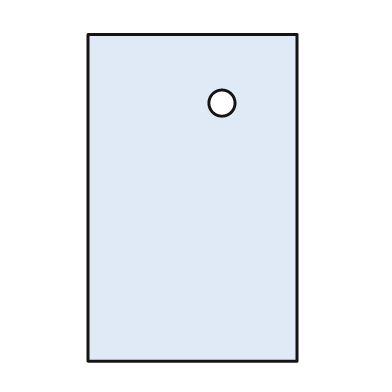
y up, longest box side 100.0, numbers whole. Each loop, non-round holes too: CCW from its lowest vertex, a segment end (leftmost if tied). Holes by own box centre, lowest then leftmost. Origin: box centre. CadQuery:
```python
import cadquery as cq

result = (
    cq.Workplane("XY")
    .moveTo(-32.0, -50.0)
    .lineTo(32.0, -50.0)
    .lineTo(32.0, 50.0)
    .lineTo(-32.0, 50.0)
    .close()
    .moveTo(9.0, 29.0)
    .circle(4.0)
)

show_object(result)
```